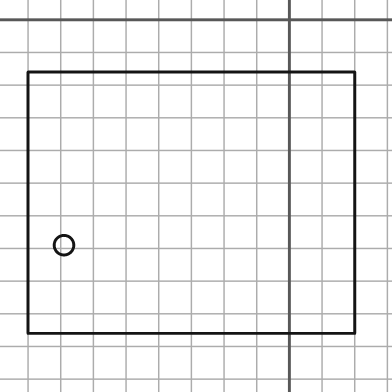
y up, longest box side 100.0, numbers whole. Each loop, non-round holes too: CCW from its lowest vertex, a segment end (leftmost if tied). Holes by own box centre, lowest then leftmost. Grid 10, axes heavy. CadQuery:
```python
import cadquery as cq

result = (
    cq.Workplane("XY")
    .moveTo(-80.0, -96.0)
    .lineTo(20.0, -96.0)
    .lineTo(20.0, -16.0)
    .lineTo(-80.0, -16.0)
    .close()
    .moveTo(-69.0, -69.0)
    .circle(3.0)
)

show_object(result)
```